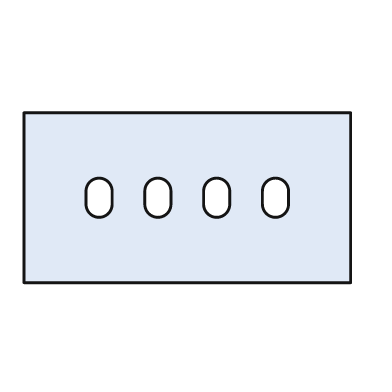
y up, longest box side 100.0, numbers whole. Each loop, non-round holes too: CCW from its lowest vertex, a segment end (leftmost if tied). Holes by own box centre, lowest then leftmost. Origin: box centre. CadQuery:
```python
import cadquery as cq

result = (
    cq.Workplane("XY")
    .moveTo(-50.0, -26.0)
    .lineTo(50.0, -26.0)
    .lineTo(50.0, 26.0)
    .lineTo(-50.0, 26.0)
    .close()
    .moveTo(-31.0, -2.0)
    .threePointArc((-27.0, -6.0), (-23.0, -2.0))
    .lineTo(-23.0, 2.0)
    .threePointArc((-27.0, 6.0), (-31.0, 2.0))
    .close()
    .moveTo(-13.0, -2.0)
    .threePointArc((-9.0, -6.0), (-5.0, -2.0))
    .lineTo(-5.0, 2.0)
    .threePointArc((-9.0, 6.0), (-13.0, 2.0))
    .close()
    .moveTo(5.0, -2.0)
    .threePointArc((9.0, -6.0), (13.0, -2.0))
    .lineTo(13.0, 2.0)
    .threePointArc((9.0, 6.0), (5.0, 2.0))
    .close()
    .moveTo(23.0, -2.0)
    .threePointArc((27.0, -6.0), (31.0, -2.0))
    .lineTo(31.0, 2.0)
    .threePointArc((27.0, 6.0), (23.0, 2.0))
    .close()
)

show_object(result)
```